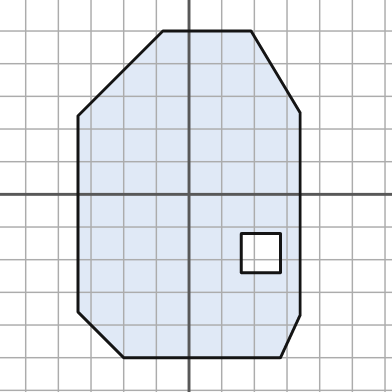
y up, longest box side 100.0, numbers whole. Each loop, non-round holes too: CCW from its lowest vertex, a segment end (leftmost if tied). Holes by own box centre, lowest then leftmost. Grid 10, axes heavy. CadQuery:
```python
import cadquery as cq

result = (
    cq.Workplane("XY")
    .moveTo(-20.0, -50.0)
    .lineTo(28.0, -50.0)
    .lineTo(34.0, -37.0)
    .lineTo(34.0, 25.0)
    .lineTo(19.0, 50.0)
    .lineTo(-8.0, 50.0)
    .lineTo(-34.0, 24.0)
    .lineTo(-34.0, -36.0)
    .close()
    .moveTo(16.0, -24.0)
    .lineTo(28.0, -24.0)
    .lineTo(28.0, -12.0)
    .lineTo(16.0, -12.0)
    .close()
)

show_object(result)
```